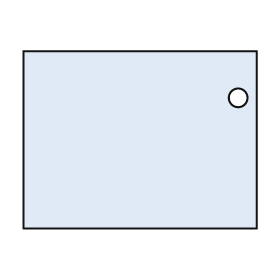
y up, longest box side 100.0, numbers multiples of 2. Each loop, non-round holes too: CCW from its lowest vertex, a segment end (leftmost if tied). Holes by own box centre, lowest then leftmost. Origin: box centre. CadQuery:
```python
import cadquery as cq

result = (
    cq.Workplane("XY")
    .moveTo(-50.0, -38.0)
    .lineTo(50.0, -38.0)
    .lineTo(50.0, 38.0)
    .lineTo(-50.0, 38.0)
    .close()
    .moveTo(42.0, 18.0)
    .circle(4.0)
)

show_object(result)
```